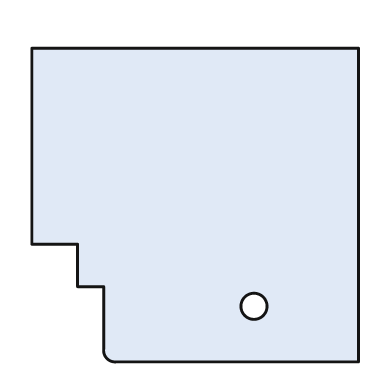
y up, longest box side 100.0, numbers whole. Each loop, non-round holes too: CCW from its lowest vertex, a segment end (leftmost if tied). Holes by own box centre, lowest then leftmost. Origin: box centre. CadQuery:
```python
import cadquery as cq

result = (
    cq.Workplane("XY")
    .moveTo(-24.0, -48.0)
    .lineTo(50.0, -48.0)
    .lineTo(50.0, 48.0)
    .lineTo(-50.0, 48.0)
    .lineTo(-50.0, -12.0)
    .lineTo(-36.0, -12.0)
    .lineTo(-36.0, -25.0)
    .lineTo(-28.0, -25.0)
    .lineTo(-28.0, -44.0)
    .threePointArc((-27.0, -47.0), (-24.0, -48.0))
    .close()
    .moveTo(18.0, -31.0)
    .circle(4.0)
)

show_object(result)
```